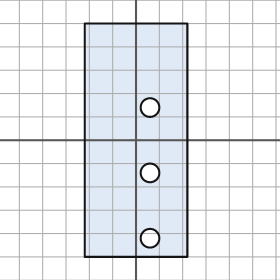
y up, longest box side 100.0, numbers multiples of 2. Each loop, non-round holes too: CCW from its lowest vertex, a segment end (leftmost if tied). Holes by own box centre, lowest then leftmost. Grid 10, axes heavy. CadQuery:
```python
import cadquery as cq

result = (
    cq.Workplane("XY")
    .moveTo(-22.0, -50.0)
    .lineTo(22.0, -50.0)
    .lineTo(22.0, 50.0)
    .lineTo(-22.0, 50.0)
    .close()
    .moveTo(6.0, -42.0)
    .circle(4.0)
    .moveTo(6.0, -14.0)
    .circle(4.0)
    .moveTo(6.0, 14.0)
    .circle(4.0)
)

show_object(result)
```